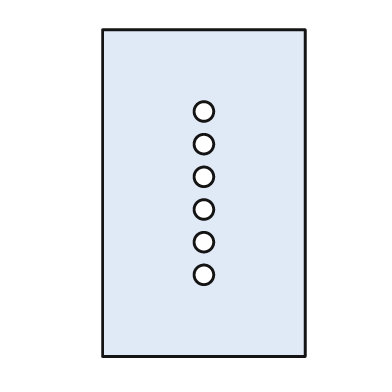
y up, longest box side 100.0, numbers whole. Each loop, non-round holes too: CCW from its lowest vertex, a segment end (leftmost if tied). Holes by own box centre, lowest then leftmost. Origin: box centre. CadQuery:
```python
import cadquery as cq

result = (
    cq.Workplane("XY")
    .moveTo(-31.0, -50.0)
    .lineTo(31.0, -50.0)
    .lineTo(31.0, 50.0)
    .lineTo(-31.0, 50.0)
    .close()
    .moveTo(0.0, -25.0)
    .circle(3.0)
    .moveTo(0.0, -15.0)
    .circle(3.0)
    .moveTo(0.0, -5.0)
    .circle(3.0)
    .moveTo(0.0, 5.0)
    .circle(3.0)
    .moveTo(0.0, 15.0)
    .circle(3.0)
    .moveTo(0.0, 25.0)
    .circle(3.0)
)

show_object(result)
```